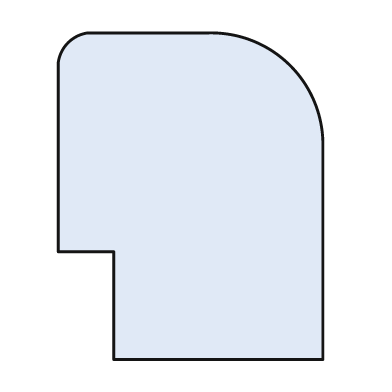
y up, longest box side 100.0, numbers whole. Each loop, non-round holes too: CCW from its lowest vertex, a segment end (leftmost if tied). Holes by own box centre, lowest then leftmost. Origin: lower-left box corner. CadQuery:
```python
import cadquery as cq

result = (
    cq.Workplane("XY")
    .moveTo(17.0, 0.0)
    .lineTo(81.0, 0.0)
    .lineTo(81.0, 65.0)
    .threePointArc((71.0, 90.0), (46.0, 100.0))
    .lineTo(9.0, 100.0)
    .threePointArc((3.0, 97.0), (0.0, 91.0))
    .lineTo(0.0, 33.0)
    .lineTo(17.0, 33.0)
    .close()
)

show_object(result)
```